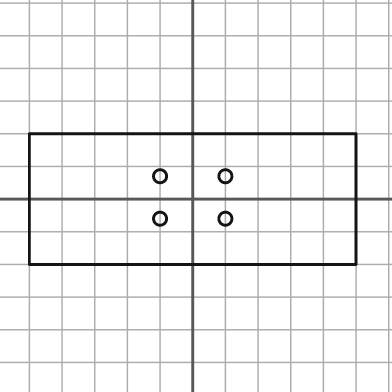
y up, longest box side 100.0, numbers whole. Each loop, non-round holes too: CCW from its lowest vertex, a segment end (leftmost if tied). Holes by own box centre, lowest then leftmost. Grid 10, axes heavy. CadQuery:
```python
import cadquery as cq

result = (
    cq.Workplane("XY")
    .moveTo(-50.0, -20.0)
    .lineTo(50.0, -20.0)
    .lineTo(50.0, 20.0)
    .lineTo(-50.0, 20.0)
    .close()
    .moveTo(-10.0, -6.0)
    .circle(2.0)
    .moveTo(10.0, -6.0)
    .circle(2.0)
    .moveTo(-10.0, 7.0)
    .circle(2.0)
    .moveTo(10.0, 7.0)
    .circle(2.0)
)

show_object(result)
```